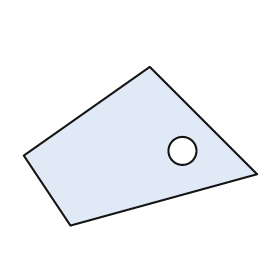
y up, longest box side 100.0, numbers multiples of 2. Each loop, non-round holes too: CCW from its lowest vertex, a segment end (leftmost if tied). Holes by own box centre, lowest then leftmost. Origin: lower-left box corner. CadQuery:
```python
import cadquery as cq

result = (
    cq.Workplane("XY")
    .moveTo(20.0, 0.0)
    .lineTo(100.0, 22.0)
    .lineTo(54.0, 68.0)
    .lineTo(0.0, 30.0)
    .close()
    .moveTo(68.0, 32.0)
    .circle(6.0)
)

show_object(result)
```